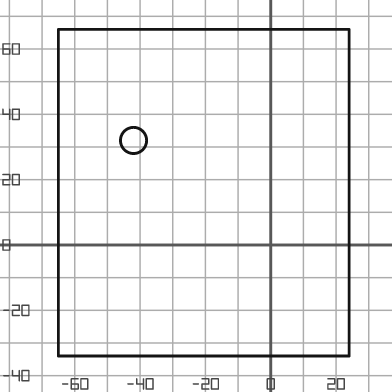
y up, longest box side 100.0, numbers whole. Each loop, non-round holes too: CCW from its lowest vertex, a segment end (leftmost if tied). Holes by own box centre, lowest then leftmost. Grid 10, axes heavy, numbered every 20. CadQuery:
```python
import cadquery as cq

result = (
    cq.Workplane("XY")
    .moveTo(-65.0, -34.0)
    .lineTo(24.0, -34.0)
    .lineTo(24.0, 66.0)
    .lineTo(-65.0, 66.0)
    .close()
    .moveTo(-42.0, 32.0)
    .circle(4.0)
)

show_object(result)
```